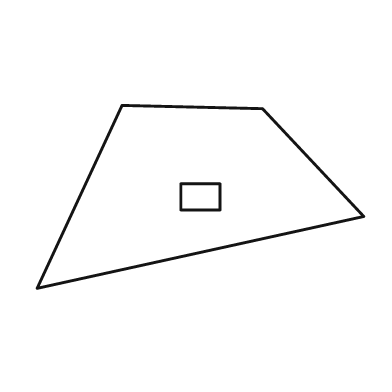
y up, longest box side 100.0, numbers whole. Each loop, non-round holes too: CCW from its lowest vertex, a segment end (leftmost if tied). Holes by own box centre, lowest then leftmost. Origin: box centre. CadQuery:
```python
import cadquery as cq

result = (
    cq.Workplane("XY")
    .moveTo(-50.0, -28.0)
    .lineTo(50.0, -6.0)
    .lineTo(19.0, 27.0)
    .lineTo(-24.0, 28.0)
    .close()
    .moveTo(-6.0, -4.0)
    .lineTo(6.0, -4.0)
    .lineTo(6.0, 4.0)
    .lineTo(-6.0, 4.0)
    .close()
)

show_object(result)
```